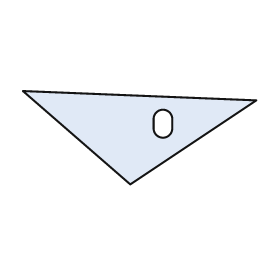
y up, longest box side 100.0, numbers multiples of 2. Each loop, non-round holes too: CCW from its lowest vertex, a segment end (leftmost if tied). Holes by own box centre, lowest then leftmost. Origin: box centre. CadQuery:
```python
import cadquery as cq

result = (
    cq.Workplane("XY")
    .moveTo(-4.0, -20.0)
    .lineTo(50.0, 16.0)
    .lineTo(-50.0, 20.0)
    .close()
    .moveTo(6.0, 4.0)
    .threePointArc((10.0, 0.0), (14.0, 4.0))
    .lineTo(14.0, 8.0)
    .threePointArc((10.0, 12.0), (6.0, 8.0))
    .close()
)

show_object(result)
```